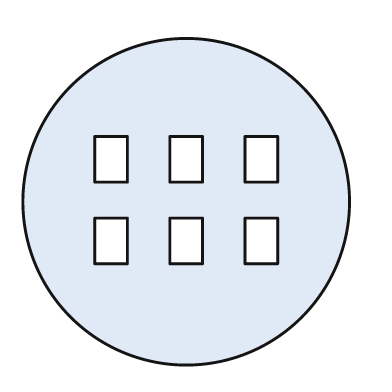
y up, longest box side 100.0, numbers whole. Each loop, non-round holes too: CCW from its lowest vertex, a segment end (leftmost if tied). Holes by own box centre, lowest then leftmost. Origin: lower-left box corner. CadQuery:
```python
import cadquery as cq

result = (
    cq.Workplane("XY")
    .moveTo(50.0, 50.0)
    .circle(50.0)
    .moveTo(22.0, 31.0)
    .lineTo(32.0, 31.0)
    .lineTo(32.0, 45.0)
    .lineTo(22.0, 45.0)
    .close()
    .moveTo(45.0, 31.0)
    .lineTo(55.0, 31.0)
    .lineTo(55.0, 45.0)
    .lineTo(45.0, 45.0)
    .close()
    .moveTo(68.0, 31.0)
    .lineTo(78.0, 31.0)
    .lineTo(78.0, 45.0)
    .lineTo(68.0, 45.0)
    .close()
    .moveTo(22.0, 56.0)
    .lineTo(32.0, 56.0)
    .lineTo(32.0, 70.0)
    .lineTo(22.0, 70.0)
    .close()
    .moveTo(45.0, 56.0)
    .lineTo(55.0, 56.0)
    .lineTo(55.0, 70.0)
    .lineTo(45.0, 70.0)
    .close()
    .moveTo(68.0, 56.0)
    .lineTo(78.0, 56.0)
    .lineTo(78.0, 70.0)
    .lineTo(68.0, 70.0)
    .close()
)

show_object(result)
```